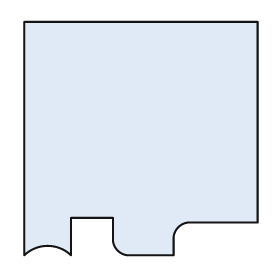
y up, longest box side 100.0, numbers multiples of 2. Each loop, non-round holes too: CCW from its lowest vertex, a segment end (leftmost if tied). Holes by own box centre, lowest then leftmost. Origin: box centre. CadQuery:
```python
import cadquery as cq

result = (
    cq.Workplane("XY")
    .moveTo(-50.0, -50.0)
    .threePointArc((-40.0, -46.0), (-30.0, -50.0))
    .lineTo(-30.0, -34.0)
    .lineTo(-12.0, -34.0)
    .lineTo(-12.0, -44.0)
    .threePointArc((-10.0, -48.0), (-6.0, -50.0))
    .lineTo(14.0, -50.0)
    .lineTo(14.0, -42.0)
    .threePointArc((16.0, -38.0), (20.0, -36.0))
    .lineTo(50.0, -36.0)
    .lineTo(50.0, 50.0)
    .lineTo(-50.0, 50.0)
    .close()
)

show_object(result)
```